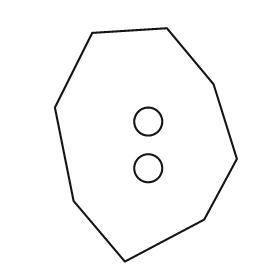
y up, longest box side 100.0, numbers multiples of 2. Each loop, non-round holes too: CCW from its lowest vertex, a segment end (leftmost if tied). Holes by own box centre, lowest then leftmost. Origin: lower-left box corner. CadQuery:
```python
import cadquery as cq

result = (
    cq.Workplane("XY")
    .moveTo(30.0, 0.0)
    .lineTo(64.0, 18.0)
    .lineTo(78.0, 44.0)
    .lineTo(68.0, 76.0)
    .lineTo(48.0, 100.0)
    .lineTo(16.0, 98.0)
    .lineTo(0.0, 66.0)
    .lineTo(8.0, 26.0)
    .close()
    .moveTo(40.0, 40.0)
    .circle(6.0)
    .moveTo(40.0, 60.0)
    .circle(6.0)
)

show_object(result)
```